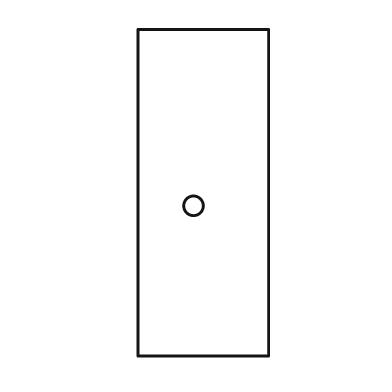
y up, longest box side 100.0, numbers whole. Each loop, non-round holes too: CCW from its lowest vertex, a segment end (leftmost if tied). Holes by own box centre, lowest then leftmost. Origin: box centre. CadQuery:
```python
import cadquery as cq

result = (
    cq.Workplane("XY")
    .moveTo(-20.0, -50.0)
    .lineTo(20.0, -50.0)
    .lineTo(20.0, 50.0)
    .lineTo(-20.0, 50.0)
    .close()
    .moveTo(-3.0, -4.0)
    .circle(3.0)
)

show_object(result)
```